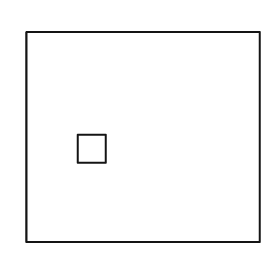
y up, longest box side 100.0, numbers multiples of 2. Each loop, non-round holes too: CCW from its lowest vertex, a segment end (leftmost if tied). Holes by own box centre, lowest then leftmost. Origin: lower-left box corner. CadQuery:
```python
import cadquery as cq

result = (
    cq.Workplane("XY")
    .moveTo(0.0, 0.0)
    .lineTo(100.0, 0.0)
    .lineTo(100.0, 90.0)
    .lineTo(0.0, 90.0)
    .close()
    .moveTo(22.0, 34.0)
    .lineTo(34.0, 34.0)
    .lineTo(34.0, 46.0)
    .lineTo(22.0, 46.0)
    .close()
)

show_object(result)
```